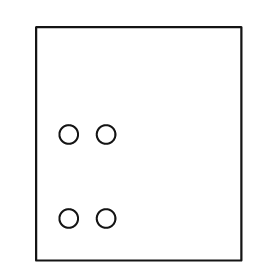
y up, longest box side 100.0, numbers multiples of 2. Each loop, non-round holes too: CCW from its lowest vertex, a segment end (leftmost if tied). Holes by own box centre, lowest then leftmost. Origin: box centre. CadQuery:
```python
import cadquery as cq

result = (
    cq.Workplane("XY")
    .moveTo(-44.0, -50.0)
    .lineTo(44.0, -50.0)
    .lineTo(44.0, 50.0)
    .lineTo(-44.0, 50.0)
    .close()
    .moveTo(-30.0, -32.0)
    .circle(4.0)
    .moveTo(-14.0, -32.0)
    .circle(4.0)
    .moveTo(-30.0, 4.0)
    .circle(4.0)
    .moveTo(-14.0, 4.0)
    .circle(4.0)
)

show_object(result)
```